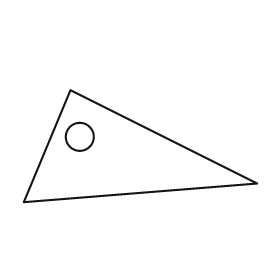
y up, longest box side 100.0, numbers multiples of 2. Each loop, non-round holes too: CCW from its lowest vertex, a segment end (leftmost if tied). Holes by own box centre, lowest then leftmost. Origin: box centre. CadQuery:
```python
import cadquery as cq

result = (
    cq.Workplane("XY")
    .moveTo(-50.0, -24.0)
    .lineTo(50.0, -16.0)
    .lineTo(-30.0, 24.0)
    .close()
    .moveTo(-26.0, 4.0)
    .circle(6.0)
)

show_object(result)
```